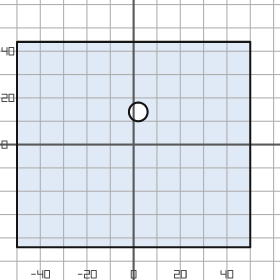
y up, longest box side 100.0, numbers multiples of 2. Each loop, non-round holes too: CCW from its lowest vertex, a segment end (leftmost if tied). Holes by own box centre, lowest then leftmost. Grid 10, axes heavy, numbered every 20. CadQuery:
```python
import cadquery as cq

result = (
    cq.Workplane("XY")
    .moveTo(-50.0, -44.0)
    .lineTo(50.0, -44.0)
    .lineTo(50.0, 44.0)
    .lineTo(-50.0, 44.0)
    .close()
    .moveTo(2.0, 14.0)
    .circle(4.0)
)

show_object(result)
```